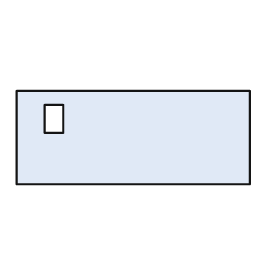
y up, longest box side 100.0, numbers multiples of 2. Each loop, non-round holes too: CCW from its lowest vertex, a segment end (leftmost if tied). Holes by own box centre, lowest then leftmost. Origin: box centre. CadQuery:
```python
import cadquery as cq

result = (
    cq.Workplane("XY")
    .moveTo(-50.0, -20.0)
    .lineTo(50.0, -20.0)
    .lineTo(50.0, 20.0)
    .lineTo(-50.0, 20.0)
    .close()
    .moveTo(-38.0, 2.0)
    .lineTo(-30.0, 2.0)
    .lineTo(-30.0, 14.0)
    .lineTo(-38.0, 14.0)
    .close()
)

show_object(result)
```